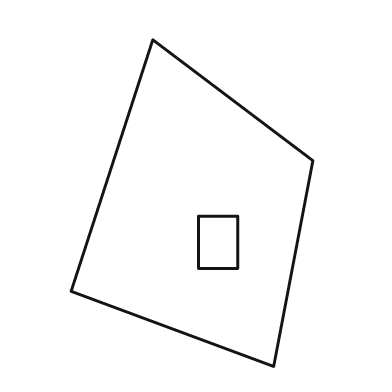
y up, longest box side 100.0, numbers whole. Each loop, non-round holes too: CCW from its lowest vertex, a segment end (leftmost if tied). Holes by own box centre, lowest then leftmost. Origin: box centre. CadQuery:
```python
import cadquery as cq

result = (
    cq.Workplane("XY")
    .moveTo(25.0, -50.0)
    .lineTo(37.0, 13.0)
    .lineTo(-12.0, 50.0)
    .lineTo(-37.0, -27.0)
    .close()
    .moveTo(2.0, -20.0)
    .lineTo(14.0, -20.0)
    .lineTo(14.0, -4.0)
    .lineTo(2.0, -4.0)
    .close()
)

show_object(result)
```